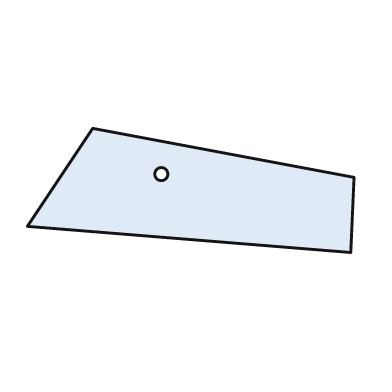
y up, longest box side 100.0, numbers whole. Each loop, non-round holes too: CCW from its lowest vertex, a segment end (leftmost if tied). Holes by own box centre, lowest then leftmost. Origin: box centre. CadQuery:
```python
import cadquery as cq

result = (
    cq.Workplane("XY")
    .moveTo(49.0, -19.0)
    .lineTo(50.0, 4.0)
    .lineTo(-30.0, 19.0)
    .lineTo(-50.0, -11.0)
    .close()
    .moveTo(-9.0, 5.0)
    .circle(2.0)
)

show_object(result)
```